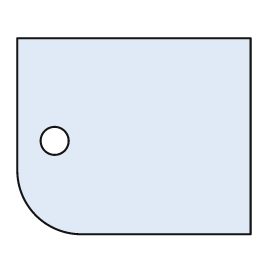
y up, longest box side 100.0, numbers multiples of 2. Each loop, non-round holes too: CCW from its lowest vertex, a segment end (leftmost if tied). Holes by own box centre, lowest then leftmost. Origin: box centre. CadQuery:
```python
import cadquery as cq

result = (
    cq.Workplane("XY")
    .moveTo(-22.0, -42.0)
    .lineTo(50.0, -42.0)
    .lineTo(50.0, 42.0)
    .lineTo(-50.0, 42.0)
    .lineTo(-50.0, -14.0)
    .threePointArc((-42.0, -34.0), (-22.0, -42.0))
    .close()
    .moveTo(-34.0, -2.0)
    .circle(6.0)
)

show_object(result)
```